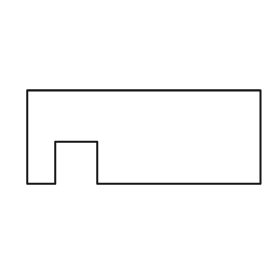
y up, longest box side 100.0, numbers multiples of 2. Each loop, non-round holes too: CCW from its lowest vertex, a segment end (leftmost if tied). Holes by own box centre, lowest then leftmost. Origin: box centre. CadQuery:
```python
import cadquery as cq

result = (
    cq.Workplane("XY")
    .moveTo(-50.0, -20.0)
    .lineTo(-38.0, -20.0)
    .lineTo(-38.0, -2.0)
    .lineTo(-20.0, -2.0)
    .lineTo(-20.0, -20.0)
    .lineTo(50.0, -20.0)
    .lineTo(50.0, 20.0)
    .lineTo(-50.0, 20.0)
    .close()
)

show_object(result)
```